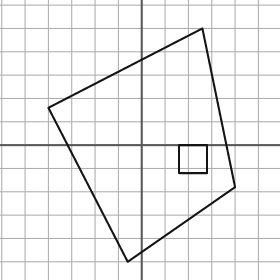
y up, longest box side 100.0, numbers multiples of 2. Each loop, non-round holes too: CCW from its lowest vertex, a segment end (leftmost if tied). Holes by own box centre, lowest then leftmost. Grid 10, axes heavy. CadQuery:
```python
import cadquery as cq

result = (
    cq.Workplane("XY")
    .moveTo(-6.0, -50.0)
    .lineTo(40.0, -18.0)
    .lineTo(26.0, 50.0)
    .lineTo(-40.0, 16.0)
    .close()
    .moveTo(16.0, -12.0)
    .lineTo(28.0, -12.0)
    .lineTo(28.0, 0.0)
    .lineTo(16.0, 0.0)
    .close()
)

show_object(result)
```